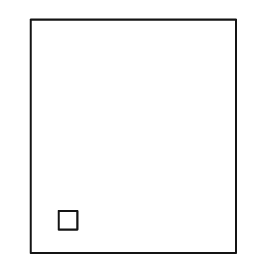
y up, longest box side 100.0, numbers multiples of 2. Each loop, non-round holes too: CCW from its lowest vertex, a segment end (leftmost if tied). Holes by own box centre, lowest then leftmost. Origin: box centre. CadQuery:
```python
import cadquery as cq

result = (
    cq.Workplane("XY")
    .moveTo(-44.0, -50.0)
    .lineTo(44.0, -50.0)
    .lineTo(44.0, 50.0)
    .lineTo(-44.0, 50.0)
    .close()
    .moveTo(-32.0, -40.0)
    .lineTo(-24.0, -40.0)
    .lineTo(-24.0, -32.0)
    .lineTo(-32.0, -32.0)
    .close()
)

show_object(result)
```